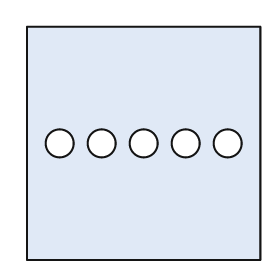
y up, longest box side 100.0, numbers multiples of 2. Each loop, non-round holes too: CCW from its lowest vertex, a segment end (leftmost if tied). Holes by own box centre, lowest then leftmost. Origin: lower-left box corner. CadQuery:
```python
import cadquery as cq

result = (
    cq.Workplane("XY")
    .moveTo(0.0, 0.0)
    .lineTo(100.0, 0.0)
    .lineTo(100.0, 100.0)
    .lineTo(0.0, 100.0)
    .close()
    .moveTo(14.0, 50.0)
    .circle(6.0)
    .moveTo(32.0, 50.0)
    .circle(6.0)
    .moveTo(50.0, 50.0)
    .circle(6.0)
    .moveTo(68.0, 50.0)
    .circle(6.0)
    .moveTo(86.0, 50.0)
    .circle(6.0)
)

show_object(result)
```